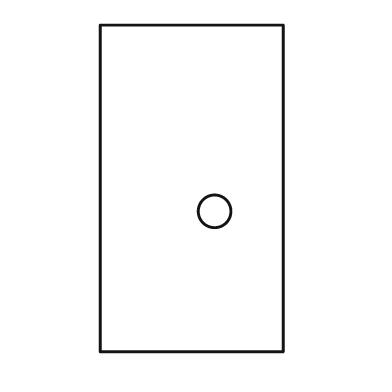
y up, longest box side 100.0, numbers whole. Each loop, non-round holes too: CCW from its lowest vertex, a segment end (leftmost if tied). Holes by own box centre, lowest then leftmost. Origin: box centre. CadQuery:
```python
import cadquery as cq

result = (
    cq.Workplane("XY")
    .moveTo(-28.0, -50.0)
    .lineTo(28.0, -50.0)
    .lineTo(28.0, 50.0)
    .lineTo(-28.0, 50.0)
    .close()
    .moveTo(7.0, -7.0)
    .circle(5.0)
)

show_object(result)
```